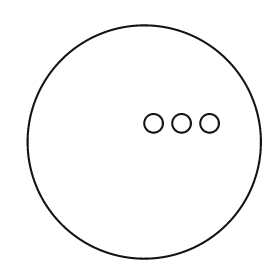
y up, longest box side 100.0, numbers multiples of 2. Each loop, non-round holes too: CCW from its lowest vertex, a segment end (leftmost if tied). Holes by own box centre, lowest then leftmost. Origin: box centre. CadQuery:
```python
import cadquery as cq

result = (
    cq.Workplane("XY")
    .moveTo(0.0, 0.0)
    .circle(50.0)
    .moveTo(4.0, 8.0)
    .circle(4.0)
    .moveTo(16.0, 8.0)
    .circle(4.0)
    .moveTo(28.0, 8.0)
    .circle(4.0)
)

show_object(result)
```